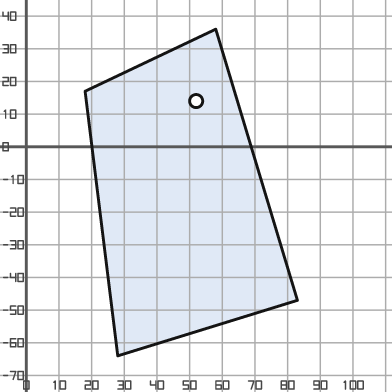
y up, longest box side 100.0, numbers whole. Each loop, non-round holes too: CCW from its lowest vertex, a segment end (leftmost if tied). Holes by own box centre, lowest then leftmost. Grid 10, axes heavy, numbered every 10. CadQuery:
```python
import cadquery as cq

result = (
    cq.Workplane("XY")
    .moveTo(28.0, -64.0)
    .lineTo(83.0, -47.0)
    .lineTo(58.0, 36.0)
    .lineTo(18.0, 17.0)
    .close()
    .moveTo(52.0, 14.0)
    .circle(2.0)
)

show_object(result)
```